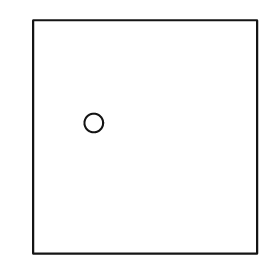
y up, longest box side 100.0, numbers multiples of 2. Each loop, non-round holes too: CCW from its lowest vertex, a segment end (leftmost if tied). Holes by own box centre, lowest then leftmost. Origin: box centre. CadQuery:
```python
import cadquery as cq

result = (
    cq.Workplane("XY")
    .moveTo(-48.0, -50.0)
    .lineTo(48.0, -50.0)
    .lineTo(48.0, 50.0)
    .lineTo(-48.0, 50.0)
    .close()
    .moveTo(-22.0, 6.0)
    .circle(4.0)
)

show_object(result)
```